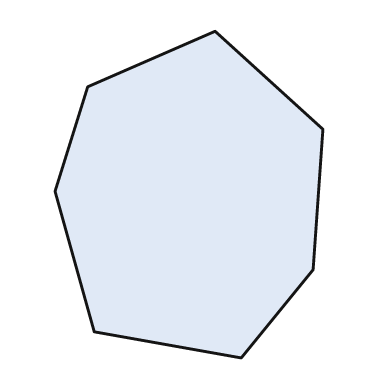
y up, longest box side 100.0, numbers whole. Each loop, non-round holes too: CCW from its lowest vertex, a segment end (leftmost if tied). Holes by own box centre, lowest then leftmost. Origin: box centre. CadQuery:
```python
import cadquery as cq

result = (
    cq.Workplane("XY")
    .moveTo(16.0, -50.0)
    .lineTo(38.0, -23.0)
    .lineTo(41.0, 20.0)
    .lineTo(8.0, 50.0)
    .lineTo(-31.0, 33.0)
    .lineTo(-41.0, 1.0)
    .lineTo(-29.0, -42.0)
    .close()
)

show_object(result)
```